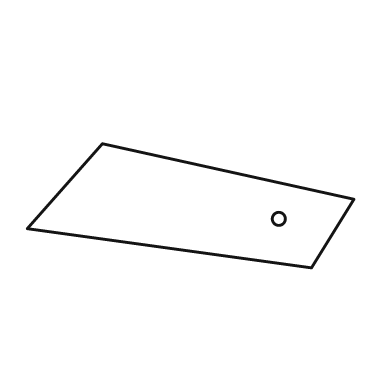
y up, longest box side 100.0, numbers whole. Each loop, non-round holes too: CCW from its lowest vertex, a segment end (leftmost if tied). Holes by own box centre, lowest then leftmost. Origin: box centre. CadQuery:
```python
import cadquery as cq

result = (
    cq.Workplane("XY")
    .moveTo(37.0, -19.0)
    .lineTo(50.0, 2.0)
    .lineTo(-27.0, 19.0)
    .lineTo(-50.0, -7.0)
    .close()
    .moveTo(27.0, -4.0)
    .circle(2.0)
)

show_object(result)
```